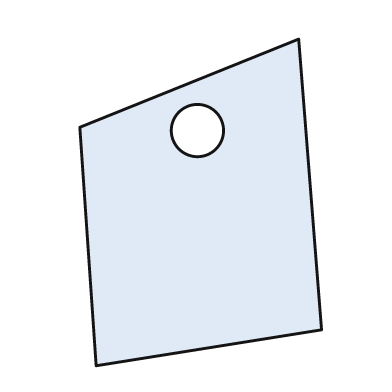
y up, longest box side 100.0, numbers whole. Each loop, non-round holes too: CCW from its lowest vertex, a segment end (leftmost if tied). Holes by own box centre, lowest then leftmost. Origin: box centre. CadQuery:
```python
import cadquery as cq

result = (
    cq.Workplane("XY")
    .moveTo(-32.0, -50.0)
    .lineTo(37.0, -39.0)
    .lineTo(30.0, 50.0)
    .lineTo(-37.0, 23.0)
    .close()
    .moveTo(-1.0, 22.0)
    .circle(8.0)
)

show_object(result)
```